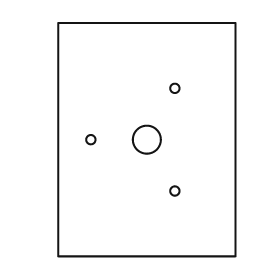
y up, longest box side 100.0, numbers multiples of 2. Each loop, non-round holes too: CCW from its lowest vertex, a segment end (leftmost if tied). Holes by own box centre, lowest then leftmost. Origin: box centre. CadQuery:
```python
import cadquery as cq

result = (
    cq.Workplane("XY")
    .moveTo(-38.0, -50.0)
    .lineTo(38.0, -50.0)
    .lineTo(38.0, 50.0)
    .lineTo(-38.0, 50.0)
    .close()
    .moveTo(12.0, -22.0)
    .circle(2.0)
    .moveTo(-24.0, 0.0)
    .circle(2.0)
    .moveTo(0.0, 0.0)
    .circle(6.0)
    .moveTo(12.0, 22.0)
    .circle(2.0)
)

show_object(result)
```